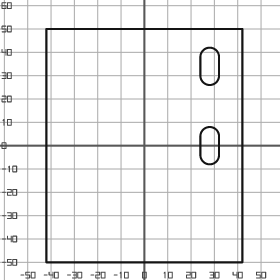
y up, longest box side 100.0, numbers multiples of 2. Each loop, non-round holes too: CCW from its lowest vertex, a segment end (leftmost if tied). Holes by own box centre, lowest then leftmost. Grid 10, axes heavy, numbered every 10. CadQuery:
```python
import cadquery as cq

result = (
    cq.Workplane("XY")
    .moveTo(-42.0, -50.0)
    .lineTo(42.0, -50.0)
    .lineTo(42.0, 50.0)
    .lineTo(-42.0, 50.0)
    .close()
    .moveTo(24.0, -4.0)
    .threePointArc((28.0, -8.0), (32.0, -4.0))
    .lineTo(32.0, 4.0)
    .threePointArc((28.0, 8.0), (24.0, 4.0))
    .close()
    .moveTo(24.0, 30.0)
    .threePointArc((28.0, 26.0), (32.0, 30.0))
    .lineTo(32.0, 38.0)
    .threePointArc((28.0, 42.0), (24.0, 38.0))
    .close()
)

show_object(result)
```